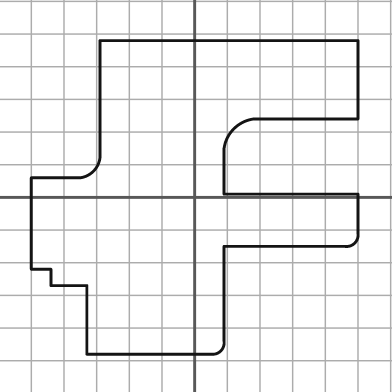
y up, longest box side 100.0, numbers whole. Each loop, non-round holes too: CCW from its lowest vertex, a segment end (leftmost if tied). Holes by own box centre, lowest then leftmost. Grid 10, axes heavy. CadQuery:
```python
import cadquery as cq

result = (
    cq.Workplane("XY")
    .moveTo(-33.0, -48.0)
    .lineTo(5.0, -48.0)
    .threePointArc((8.0, -47.0), (9.0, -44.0))
    .lineTo(9.0, -15.0)
    .lineTo(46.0, -15.0)
    .threePointArc((49.0, -14.0), (50.0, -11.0))
    .lineTo(50.0, 1.0)
    .lineTo(9.0, 1.0)
    .lineTo(9.0, 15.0)
    .threePointArc((12.0, 21.0), (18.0, 24.0))
    .lineTo(50.0, 24.0)
    .lineTo(50.0, 48.0)
    .lineTo(-29.0, 48.0)
    .lineTo(-29.0, 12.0)
    .threePointArc((-31.0, 8.0), (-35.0, 6.0))
    .lineTo(-50.0, 6.0)
    .lineTo(-50.0, -22.0)
    .lineTo(-44.0, -22.0)
    .lineTo(-44.0, -27.0)
    .lineTo(-33.0, -27.0)
    .close()
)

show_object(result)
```